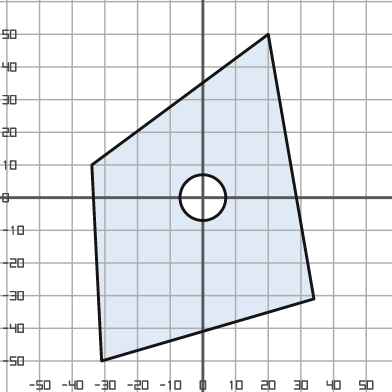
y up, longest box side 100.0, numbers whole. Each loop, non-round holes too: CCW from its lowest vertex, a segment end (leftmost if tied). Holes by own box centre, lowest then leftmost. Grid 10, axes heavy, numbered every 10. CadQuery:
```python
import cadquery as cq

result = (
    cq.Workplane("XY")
    .moveTo(-31.0, -50.0)
    .lineTo(34.0, -31.0)
    .lineTo(20.0, 50.0)
    .lineTo(-34.0, 10.0)
    .close()
    .moveTo(0.0, 0.0)
    .circle(7.0)
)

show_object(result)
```